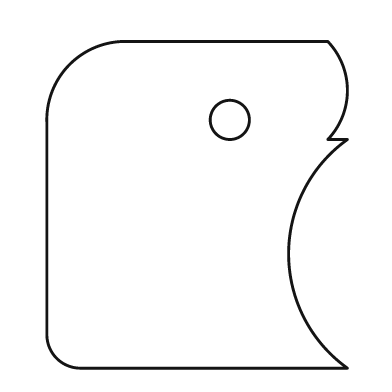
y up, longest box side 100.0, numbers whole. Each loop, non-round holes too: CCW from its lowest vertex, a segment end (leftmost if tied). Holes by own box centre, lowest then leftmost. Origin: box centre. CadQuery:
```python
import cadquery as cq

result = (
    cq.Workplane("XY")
    .moveTo(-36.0, -50.0)
    .lineTo(46.0, -50.0)
    .threePointArc((28.0, -15.0), (46.0, 20.0))
    .lineTo(40.0, 20.0)
    .threePointArc((46.0, 35.0), (40.0, 50.0))
    .lineTo(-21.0, 50.0)
    .threePointArc((-39.0, 43.0), (-46.0, 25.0))
    .lineTo(-46.0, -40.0)
    .threePointArc((-43.0, -47.0), (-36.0, -50.0))
    .close()
    .moveTo(10.0, 26.0)
    .circle(6.0)
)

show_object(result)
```